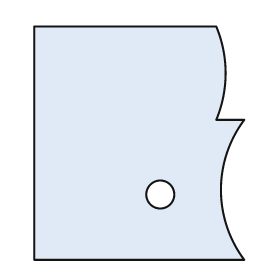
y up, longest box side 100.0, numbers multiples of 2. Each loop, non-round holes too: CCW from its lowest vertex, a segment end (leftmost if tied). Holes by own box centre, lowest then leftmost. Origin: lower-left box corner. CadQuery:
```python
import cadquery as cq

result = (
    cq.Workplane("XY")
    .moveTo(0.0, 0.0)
    .lineTo(90.0, 0.0)
    .threePointArc((80.0, 30.0), (90.0, 60.0))
    .lineTo(78.0, 60.0)
    .threePointArc((82.0, 80.0), (78.0, 100.0))
    .lineTo(0.0, 100.0)
    .close()
    .moveTo(54.0, 28.0)
    .circle(6.0)
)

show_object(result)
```